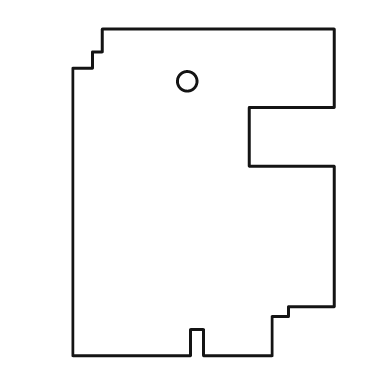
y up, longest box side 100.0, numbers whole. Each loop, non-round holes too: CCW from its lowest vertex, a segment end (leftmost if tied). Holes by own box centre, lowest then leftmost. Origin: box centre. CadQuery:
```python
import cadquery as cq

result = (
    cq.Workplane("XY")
    .moveTo(-40.0, -50.0)
    .lineTo(-4.0, -50.0)
    .lineTo(-4.0, -42.0)
    .lineTo(0.0, -42.0)
    .lineTo(0.0, -50.0)
    .lineTo(21.0, -50.0)
    .lineTo(21.0, -38.0)
    .lineTo(26.0, -38.0)
    .lineTo(26.0, -35.0)
    .lineTo(40.0, -35.0)
    .lineTo(40.0, 8.0)
    .lineTo(14.0, 8.0)
    .lineTo(14.0, 26.0)
    .lineTo(40.0, 26.0)
    .lineTo(40.0, 50.0)
    .lineTo(-31.0, 50.0)
    .lineTo(-31.0, 43.0)
    .lineTo(-34.0, 43.0)
    .lineTo(-34.0, 38.0)
    .lineTo(-40.0, 38.0)
    .close()
    .moveTo(-5.0, 34.0)
    .circle(3.0)
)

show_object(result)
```